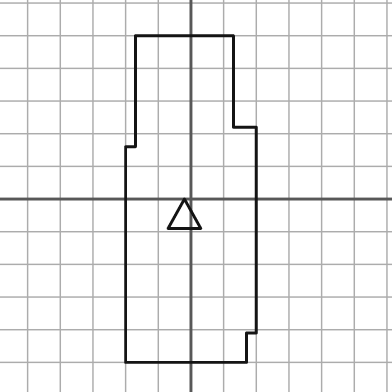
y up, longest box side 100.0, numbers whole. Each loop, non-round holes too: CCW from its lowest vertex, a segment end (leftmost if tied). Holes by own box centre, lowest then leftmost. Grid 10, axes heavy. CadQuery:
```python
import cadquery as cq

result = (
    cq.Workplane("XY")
    .moveTo(-20.0, -50.0)
    .lineTo(17.0, -50.0)
    .lineTo(17.0, -41.0)
    .lineTo(20.0, -41.0)
    .lineTo(20.0, 22.0)
    .lineTo(13.0, 22.0)
    .lineTo(13.0, 50.0)
    .lineTo(-17.0, 50.0)
    .lineTo(-17.0, 16.0)
    .lineTo(-20.0, 16.0)
    .close()
    .moveTo(-7.0, -9.0)
    .lineTo(3.0, -9.0)
    .lineTo(-2.0, 0.0)
    .close()
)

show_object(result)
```